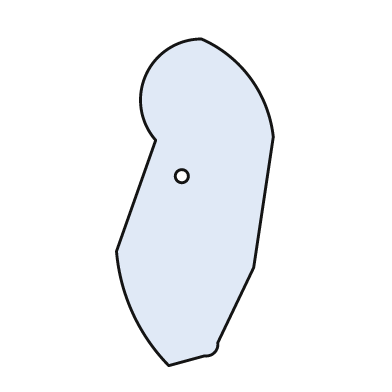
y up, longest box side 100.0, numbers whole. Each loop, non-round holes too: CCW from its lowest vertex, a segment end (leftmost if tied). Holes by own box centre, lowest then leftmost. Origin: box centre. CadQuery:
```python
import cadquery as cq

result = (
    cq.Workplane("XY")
    .moveTo(-8.0, -50.0)
    .lineTo(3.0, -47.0)
    .threePointArc((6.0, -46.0), (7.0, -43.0))
    .lineTo(18.0, -20.0)
    .lineTo(24.0, 20.0)
    .threePointArc((17.0, 38.0), (2.0, 50.0))
    .threePointArc((-15.0, 39.0), (-12.0, 19.0))
    .lineTo(-24.0, -15.0)
    .threePointArc((-19.0, -34.0), (-8.0, -50.0))
    .close()
    .moveTo(-4.0, 8.0)
    .circle(2.0)
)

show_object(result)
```